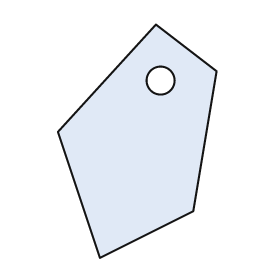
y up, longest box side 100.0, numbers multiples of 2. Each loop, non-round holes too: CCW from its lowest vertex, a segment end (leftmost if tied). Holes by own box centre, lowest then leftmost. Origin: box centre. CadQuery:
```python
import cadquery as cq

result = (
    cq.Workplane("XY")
    .moveTo(-16.0, -50.0)
    .lineTo(24.0, -30.0)
    .lineTo(34.0, 30.0)
    .lineTo(8.0, 50.0)
    .lineTo(-34.0, 4.0)
    .close()
    .moveTo(10.0, 26.0)
    .circle(6.0)
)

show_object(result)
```